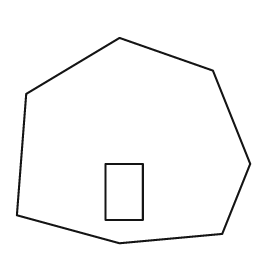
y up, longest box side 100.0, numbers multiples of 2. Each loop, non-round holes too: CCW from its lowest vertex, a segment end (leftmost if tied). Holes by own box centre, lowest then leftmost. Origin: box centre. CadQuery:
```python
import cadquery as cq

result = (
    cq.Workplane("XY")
    .moveTo(-6.0, -44.0)
    .lineTo(38.0, -40.0)
    .lineTo(50.0, -10.0)
    .lineTo(34.0, 30.0)
    .lineTo(-6.0, 44.0)
    .lineTo(-46.0, 20.0)
    .lineTo(-50.0, -32.0)
    .close()
    .moveTo(-12.0, -34.0)
    .lineTo(4.0, -34.0)
    .lineTo(4.0, -10.0)
    .lineTo(-12.0, -10.0)
    .close()
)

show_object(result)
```